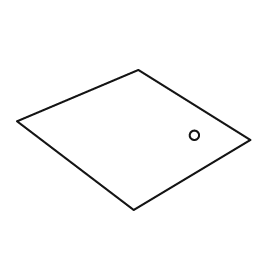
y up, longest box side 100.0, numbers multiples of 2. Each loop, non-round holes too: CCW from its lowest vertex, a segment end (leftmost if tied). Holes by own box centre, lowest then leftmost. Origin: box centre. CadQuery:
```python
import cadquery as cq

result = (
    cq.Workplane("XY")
    .moveTo(0.0, -30.0)
    .lineTo(50.0, 0.0)
    .lineTo(2.0, 30.0)
    .lineTo(-50.0, 8.0)
    .close()
    .moveTo(26.0, 2.0)
    .circle(2.0)
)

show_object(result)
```